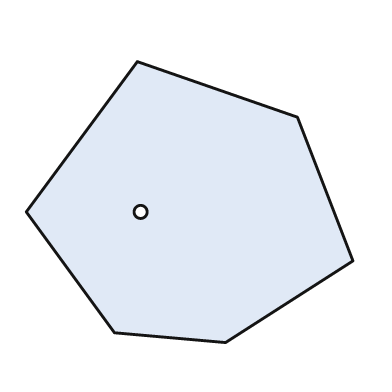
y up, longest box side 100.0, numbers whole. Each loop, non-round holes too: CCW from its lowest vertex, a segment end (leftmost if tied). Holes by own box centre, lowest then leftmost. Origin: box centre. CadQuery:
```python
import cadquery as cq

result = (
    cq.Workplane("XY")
    .moveTo(11.0, -43.0)
    .lineTo(50.0, -18.0)
    .lineTo(33.0, 26.0)
    .lineTo(-16.0, 43.0)
    .lineTo(-50.0, -3.0)
    .lineTo(-23.0, -40.0)
    .close()
    .moveTo(-15.0, -3.0)
    .circle(2.0)
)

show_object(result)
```